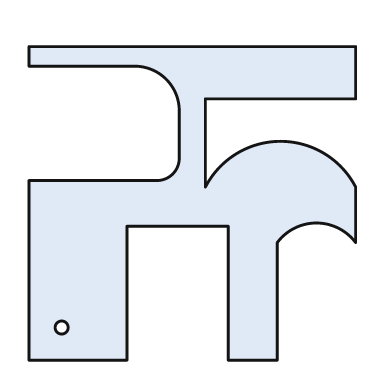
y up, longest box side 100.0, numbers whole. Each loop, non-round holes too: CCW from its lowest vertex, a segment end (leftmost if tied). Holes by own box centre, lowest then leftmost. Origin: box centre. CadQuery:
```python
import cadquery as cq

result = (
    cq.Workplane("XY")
    .moveTo(-50.0, -48.0)
    .lineTo(-20.0, -48.0)
    .lineTo(-20.0, -7.0)
    .lineTo(11.0, -7.0)
    .lineTo(11.0, -48.0)
    .lineTo(26.0, -48.0)
    .lineTo(26.0, -12.0)
    .threePointArc((38.0, -6.0), (50.0, -12.0))
    .lineTo(50.0, 5.0)
    .threePointArc((27.0, 19.0), (4.0, 5.0))
    .lineTo(4.0, 32.0)
    .lineTo(50.0, 32.0)
    .lineTo(50.0, 48.0)
    .lineTo(-50.0, 48.0)
    .lineTo(-50.0, 42.0)
    .lineTo(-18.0, 42.0)
    .threePointArc((-8.0, 38.0), (-4.0, 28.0))
    .lineTo(-4.0, 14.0)
    .threePointArc((-6.0, 9.0), (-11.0, 7.0))
    .lineTo(-50.0, 7.0)
    .close()
    .moveTo(-40.0, -38.0)
    .circle(2.0)
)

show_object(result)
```